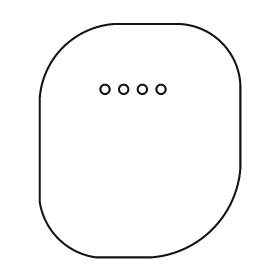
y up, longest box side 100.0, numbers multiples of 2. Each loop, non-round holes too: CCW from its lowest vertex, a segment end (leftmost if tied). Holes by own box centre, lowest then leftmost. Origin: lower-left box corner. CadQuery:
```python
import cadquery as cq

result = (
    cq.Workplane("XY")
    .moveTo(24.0, 0.0)
    .lineTo(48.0, 0.0)
    .threePointArc((74.0, 12.0), (86.0, 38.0))
    .lineTo(86.0, 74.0)
    .threePointArc((78.0, 92.0), (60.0, 100.0))
    .lineTo(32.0, 100.0)
    .threePointArc((10.0, 90.0), (0.0, 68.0))
    .lineTo(0.0, 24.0)
    .threePointArc((8.0, 8.0), (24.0, 0.0))
    .close()
    .moveTo(28.0, 72.0)
    .circle(2.0)
    .moveTo(36.0, 72.0)
    .circle(2.0)
    .moveTo(44.0, 72.0)
    .circle(2.0)
    .moveTo(52.0, 72.0)
    .circle(2.0)
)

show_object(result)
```